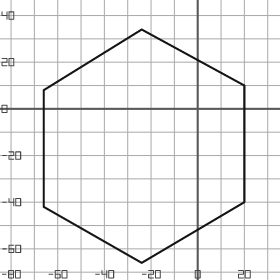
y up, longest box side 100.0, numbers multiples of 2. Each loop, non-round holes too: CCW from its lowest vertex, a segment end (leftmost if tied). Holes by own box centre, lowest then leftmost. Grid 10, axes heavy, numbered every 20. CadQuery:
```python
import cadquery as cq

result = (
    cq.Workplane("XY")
    .moveTo(-24.0, -66.0)
    .lineTo(20.0, -40.0)
    .lineTo(20.0, 10.0)
    .lineTo(-24.0, 34.0)
    .lineTo(-66.0, 8.0)
    .lineTo(-66.0, -42.0)
    .close()
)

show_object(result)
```